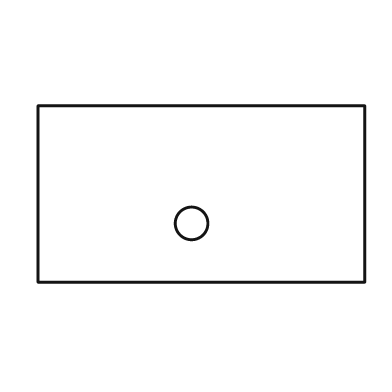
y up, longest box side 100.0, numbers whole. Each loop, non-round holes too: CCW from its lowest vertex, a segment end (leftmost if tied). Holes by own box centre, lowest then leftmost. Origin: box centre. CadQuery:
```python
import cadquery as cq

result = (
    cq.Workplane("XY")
    .moveTo(-50.0, -27.0)
    .lineTo(50.0, -27.0)
    .lineTo(50.0, 27.0)
    .lineTo(-50.0, 27.0)
    .close()
    .moveTo(-3.0, -9.0)
    .circle(5.0)
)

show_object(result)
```